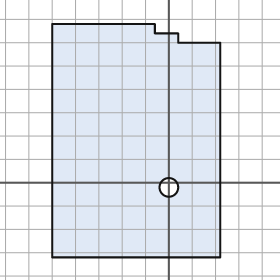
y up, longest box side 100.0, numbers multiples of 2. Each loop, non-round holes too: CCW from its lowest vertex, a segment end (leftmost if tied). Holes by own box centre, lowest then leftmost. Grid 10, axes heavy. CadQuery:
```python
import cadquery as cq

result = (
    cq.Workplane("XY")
    .moveTo(-50.0, -32.0)
    .lineTo(22.0, -32.0)
    .lineTo(22.0, 60.0)
    .lineTo(4.0, 60.0)
    .lineTo(4.0, 64.0)
    .lineTo(-6.0, 64.0)
    .lineTo(-6.0, 68.0)
    .lineTo(-50.0, 68.0)
    .close()
    .moveTo(0.0, -2.0)
    .circle(4.0)
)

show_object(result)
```